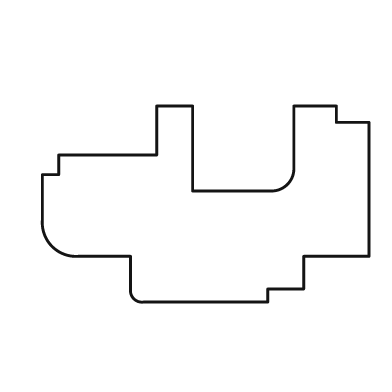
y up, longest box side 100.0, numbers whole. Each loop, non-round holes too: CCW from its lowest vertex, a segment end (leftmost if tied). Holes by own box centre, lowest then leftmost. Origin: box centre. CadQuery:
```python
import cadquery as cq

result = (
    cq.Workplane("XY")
    .moveTo(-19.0, -30.0)
    .lineTo(19.0, -30.0)
    .lineTo(19.0, -26.0)
    .lineTo(30.0, -26.0)
    .lineTo(30.0, -16.0)
    .lineTo(50.0, -16.0)
    .lineTo(50.0, 25.0)
    .lineTo(40.0, 25.0)
    .lineTo(40.0, 30.0)
    .lineTo(27.0, 30.0)
    .lineTo(27.0, 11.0)
    .threePointArc((25.0, 6.0), (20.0, 4.0))
    .lineTo(-4.0, 4.0)
    .lineTo(-4.0, 30.0)
    .lineTo(-15.0, 30.0)
    .lineTo(-15.0, 15.0)
    .lineTo(-45.0, 15.0)
    .lineTo(-45.0, 9.0)
    .lineTo(-50.0, 9.0)
    .lineTo(-50.0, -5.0)
    .threePointArc((-47.0, -13.0), (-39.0, -16.0))
    .lineTo(-23.0, -16.0)
    .lineTo(-23.0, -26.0)
    .threePointArc((-22.0, -29.0), (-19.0, -30.0))
    .close()
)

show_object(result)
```